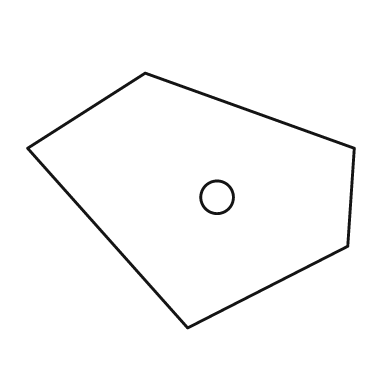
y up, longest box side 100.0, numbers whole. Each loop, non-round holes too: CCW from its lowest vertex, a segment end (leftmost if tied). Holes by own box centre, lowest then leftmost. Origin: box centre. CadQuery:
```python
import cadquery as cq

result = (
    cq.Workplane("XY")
    .moveTo(-1.0, -39.0)
    .lineTo(48.0, -14.0)
    .lineTo(50.0, 16.0)
    .lineTo(-14.0, 39.0)
    .lineTo(-50.0, 16.0)
    .close()
    .moveTo(8.0, 1.0)
    .circle(5.0)
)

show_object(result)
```